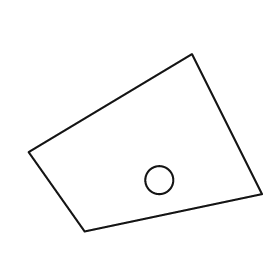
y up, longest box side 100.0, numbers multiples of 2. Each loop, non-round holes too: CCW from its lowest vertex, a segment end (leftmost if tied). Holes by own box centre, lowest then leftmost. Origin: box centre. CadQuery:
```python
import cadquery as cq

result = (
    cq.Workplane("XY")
    .moveTo(-26.0, -38.0)
    .lineTo(50.0, -22.0)
    .lineTo(20.0, 38.0)
    .lineTo(-50.0, -4.0)
    .close()
    .moveTo(6.0, -16.0)
    .circle(6.0)
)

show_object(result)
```